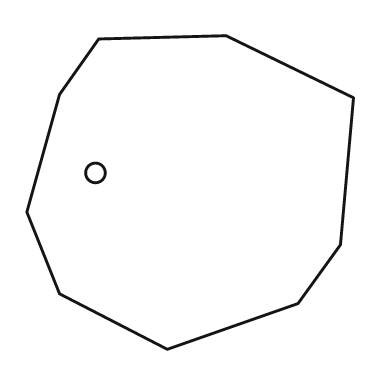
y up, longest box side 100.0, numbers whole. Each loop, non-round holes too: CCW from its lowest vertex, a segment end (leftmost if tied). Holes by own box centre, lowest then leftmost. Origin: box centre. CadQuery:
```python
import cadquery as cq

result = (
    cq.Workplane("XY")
    .moveTo(-7.0, -48.0)
    .lineTo(33.0, -34.0)
    .lineTo(46.0, -16.0)
    .lineTo(50.0, 29.0)
    .lineTo(11.0, 48.0)
    .lineTo(-28.0, 47.0)
    .lineTo(-40.0, 30.0)
    .lineTo(-50.0, -6.0)
    .lineTo(-40.0, -31.0)
    .close()
    .moveTo(-29.0, 6.0)
    .circle(3.0)
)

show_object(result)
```